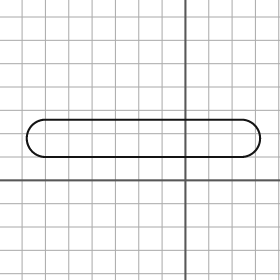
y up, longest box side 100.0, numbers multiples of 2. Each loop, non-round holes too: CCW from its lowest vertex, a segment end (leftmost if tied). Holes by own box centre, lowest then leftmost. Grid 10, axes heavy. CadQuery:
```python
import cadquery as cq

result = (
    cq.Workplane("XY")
    .moveTo(-60.0, 10.0)
    .lineTo(24.0, 10.0)
    .threePointArc((32.0, 18.0), (24.0, 26.0))
    .lineTo(-60.0, 26.0)
    .threePointArc((-68.0, 18.0), (-60.0, 10.0))
    .close()
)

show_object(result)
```